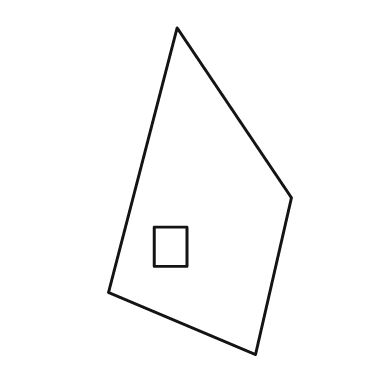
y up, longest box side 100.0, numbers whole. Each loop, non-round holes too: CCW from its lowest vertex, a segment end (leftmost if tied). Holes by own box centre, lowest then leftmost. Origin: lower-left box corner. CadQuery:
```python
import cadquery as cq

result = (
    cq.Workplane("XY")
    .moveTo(45.0, 0.0)
    .lineTo(56.0, 48.0)
    .lineTo(21.0, 100.0)
    .lineTo(0.0, 19.0)
    .close()
    .moveTo(14.0, 27.0)
    .lineTo(24.0, 27.0)
    .lineTo(24.0, 39.0)
    .lineTo(14.0, 39.0)
    .close()
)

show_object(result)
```